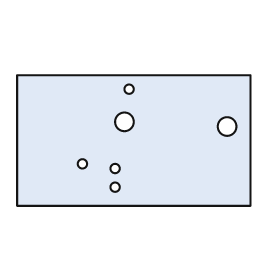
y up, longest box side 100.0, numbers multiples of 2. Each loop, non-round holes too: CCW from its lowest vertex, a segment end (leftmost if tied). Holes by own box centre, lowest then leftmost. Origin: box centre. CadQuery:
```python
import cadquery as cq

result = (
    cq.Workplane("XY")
    .moveTo(-50.0, -28.0)
    .lineTo(50.0, -28.0)
    .lineTo(50.0, 28.0)
    .lineTo(-50.0, 28.0)
    .close()
    .moveTo(-8.0, -20.0)
    .circle(2.0)
    .moveTo(-8.0, -12.0)
    .circle(2.0)
    .moveTo(-22.0, -10.0)
    .circle(2.0)
    .moveTo(40.0, 6.0)
    .circle(4.0)
    .moveTo(-4.0, 8.0)
    .circle(4.0)
    .moveTo(-2.0, 22.0)
    .circle(2.0)
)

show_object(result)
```